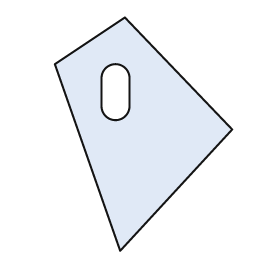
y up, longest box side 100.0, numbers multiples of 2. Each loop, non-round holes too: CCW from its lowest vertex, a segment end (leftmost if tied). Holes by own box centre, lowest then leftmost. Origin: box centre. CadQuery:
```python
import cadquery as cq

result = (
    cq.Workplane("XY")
    .moveTo(-10.0, -50.0)
    .lineTo(38.0, 2.0)
    .lineTo(-8.0, 50.0)
    .lineTo(-38.0, 30.0)
    .close()
    .moveTo(-18.0, 12.0)
    .threePointArc((-12.0, 6.0), (-6.0, 12.0))
    .lineTo(-6.0, 24.0)
    .threePointArc((-12.0, 30.0), (-18.0, 24.0))
    .close()
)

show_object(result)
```